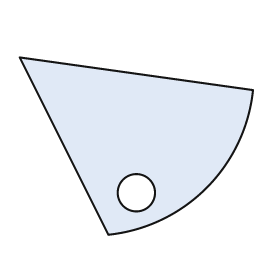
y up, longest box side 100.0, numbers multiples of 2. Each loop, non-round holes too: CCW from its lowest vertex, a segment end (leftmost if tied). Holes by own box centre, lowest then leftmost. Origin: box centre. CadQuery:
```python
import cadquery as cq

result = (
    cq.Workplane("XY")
    .moveTo(-12.0, -38.0)
    .threePointArc((30.0, -18.0), (50.0, 24.0))
    .lineTo(-50.0, 38.0)
    .close()
    .moveTo(0.0, -20.0)
    .circle(8.0)
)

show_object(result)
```